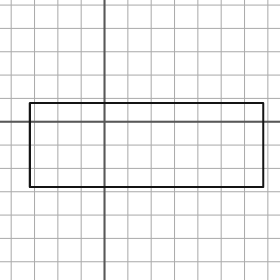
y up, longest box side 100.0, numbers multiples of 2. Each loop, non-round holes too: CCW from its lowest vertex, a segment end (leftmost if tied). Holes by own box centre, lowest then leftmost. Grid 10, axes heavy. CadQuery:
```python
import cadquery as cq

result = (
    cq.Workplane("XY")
    .moveTo(-32.0, -28.0)
    .lineTo(68.0, -28.0)
    .lineTo(68.0, 8.0)
    .lineTo(-32.0, 8.0)
    .close()
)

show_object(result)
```